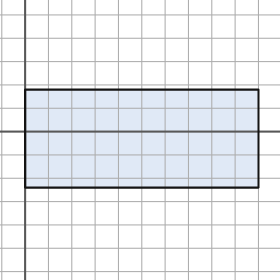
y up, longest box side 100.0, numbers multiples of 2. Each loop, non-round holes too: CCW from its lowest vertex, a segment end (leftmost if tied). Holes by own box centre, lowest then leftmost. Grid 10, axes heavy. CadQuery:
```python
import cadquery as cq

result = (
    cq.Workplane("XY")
    .moveTo(0.0, -24.0)
    .lineTo(100.0, -24.0)
    .lineTo(100.0, 18.0)
    .lineTo(0.0, 18.0)
    .close()
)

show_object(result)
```